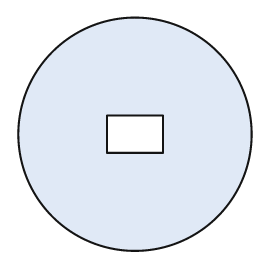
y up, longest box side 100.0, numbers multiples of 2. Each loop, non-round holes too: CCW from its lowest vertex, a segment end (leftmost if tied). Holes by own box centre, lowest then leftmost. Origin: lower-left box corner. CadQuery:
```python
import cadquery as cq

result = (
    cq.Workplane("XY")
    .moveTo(50.0, 50.0)
    .circle(50.0)
    .moveTo(38.0, 42.0)
    .lineTo(62.0, 42.0)
    .lineTo(62.0, 58.0)
    .lineTo(38.0, 58.0)
    .close()
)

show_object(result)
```